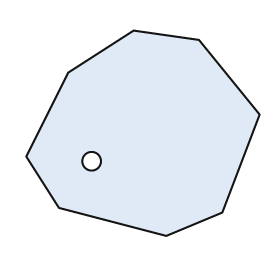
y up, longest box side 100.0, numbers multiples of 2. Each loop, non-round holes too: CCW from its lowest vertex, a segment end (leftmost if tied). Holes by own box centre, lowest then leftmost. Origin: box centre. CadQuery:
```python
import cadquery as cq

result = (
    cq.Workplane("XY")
    .moveTo(10.0, -44.0)
    .lineTo(34.0, -34.0)
    .lineTo(50.0, 8.0)
    .lineTo(24.0, 40.0)
    .lineTo(-4.0, 44.0)
    .lineTo(-32.0, 26.0)
    .lineTo(-50.0, -10.0)
    .lineTo(-36.0, -32.0)
    .close()
    .moveTo(-22.0, -12.0)
    .circle(4.0)
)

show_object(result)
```